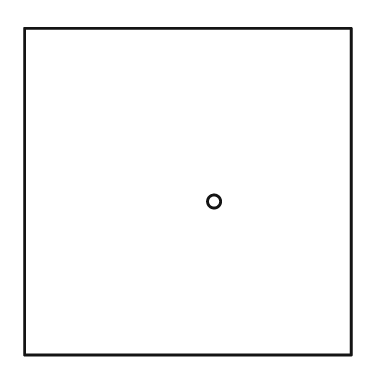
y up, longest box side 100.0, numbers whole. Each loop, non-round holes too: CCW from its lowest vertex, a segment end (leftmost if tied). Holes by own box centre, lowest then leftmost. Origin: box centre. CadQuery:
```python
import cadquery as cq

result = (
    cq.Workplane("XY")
    .moveTo(-50.0, -50.0)
    .lineTo(50.0, -50.0)
    .lineTo(50.0, 50.0)
    .lineTo(-50.0, 50.0)
    .close()
    .moveTo(8.0, -3.0)
    .circle(2.0)
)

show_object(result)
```